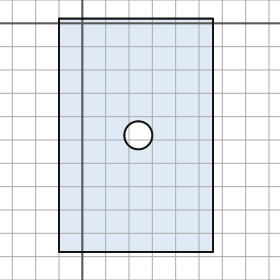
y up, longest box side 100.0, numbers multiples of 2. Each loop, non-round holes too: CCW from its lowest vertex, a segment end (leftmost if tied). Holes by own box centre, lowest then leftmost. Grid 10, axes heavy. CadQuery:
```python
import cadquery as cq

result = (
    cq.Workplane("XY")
    .moveTo(-10.0, -98.0)
    .lineTo(56.0, -98.0)
    .lineTo(56.0, 2.0)
    .lineTo(-10.0, 2.0)
    .close()
    .moveTo(24.0, -48.0)
    .circle(6.0)
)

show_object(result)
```